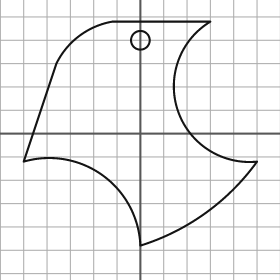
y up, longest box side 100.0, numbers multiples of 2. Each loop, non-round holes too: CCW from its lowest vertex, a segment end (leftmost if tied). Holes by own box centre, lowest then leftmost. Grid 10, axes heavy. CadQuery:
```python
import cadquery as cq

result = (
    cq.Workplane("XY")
    .moveTo(0.0, -48.0)
    .threePointArc((28.0, -34.0), (50.0, -12.0))
    .threePointArc((16.0, 10.0), (30.0, 48.0))
    .lineTo(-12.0, 48.0)
    .threePointArc((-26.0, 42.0), (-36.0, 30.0))
    .lineTo(-50.0, -12.0)
    .threePointArc((-16.0, -18.0), (0.0, -48.0))
    .close()
    .moveTo(0.0, 40.0)
    .circle(4.0)
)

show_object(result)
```